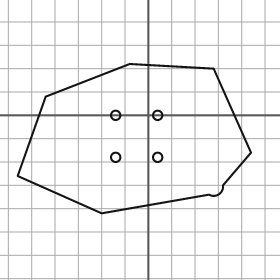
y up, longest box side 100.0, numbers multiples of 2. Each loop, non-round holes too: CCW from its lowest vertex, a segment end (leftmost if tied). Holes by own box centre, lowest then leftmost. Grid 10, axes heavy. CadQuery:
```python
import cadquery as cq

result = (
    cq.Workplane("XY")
    .moveTo(-20.0, -42.0)
    .lineTo(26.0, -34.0)
    .threePointArc((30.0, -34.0), (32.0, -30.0))
    .lineTo(44.0, -16.0)
    .lineTo(28.0, 20.0)
    .lineTo(-8.0, 22.0)
    .lineTo(-44.0, 8.0)
    .lineTo(-56.0, -26.0)
    .close()
    .moveTo(-14.0, -18.0)
    .circle(2.0)
    .moveTo(4.0, -18.0)
    .circle(2.0)
    .moveTo(-14.0, 0.0)
    .circle(2.0)
    .moveTo(4.0, 0.0)
    .circle(2.0)
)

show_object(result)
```